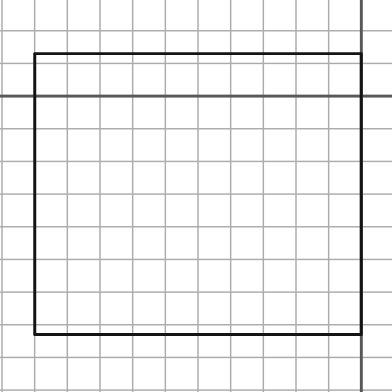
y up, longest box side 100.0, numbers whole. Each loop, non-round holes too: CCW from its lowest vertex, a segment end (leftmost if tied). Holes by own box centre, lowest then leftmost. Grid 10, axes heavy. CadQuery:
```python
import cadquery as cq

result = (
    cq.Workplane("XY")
    .moveTo(-100.0, -73.0)
    .lineTo(0.0, -73.0)
    .lineTo(0.0, 13.0)
    .lineTo(-100.0, 13.0)
    .close()
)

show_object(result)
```